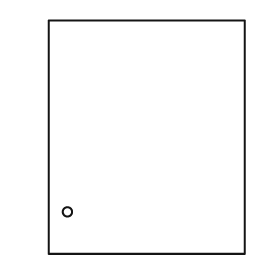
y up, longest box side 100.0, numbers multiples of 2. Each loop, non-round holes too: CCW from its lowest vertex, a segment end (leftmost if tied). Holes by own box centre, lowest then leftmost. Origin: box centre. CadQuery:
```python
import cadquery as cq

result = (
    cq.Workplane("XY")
    .moveTo(-42.0, -50.0)
    .lineTo(42.0, -50.0)
    .lineTo(42.0, 50.0)
    .lineTo(-42.0, 50.0)
    .close()
    .moveTo(-34.0, -32.0)
    .circle(2.0)
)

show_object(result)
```